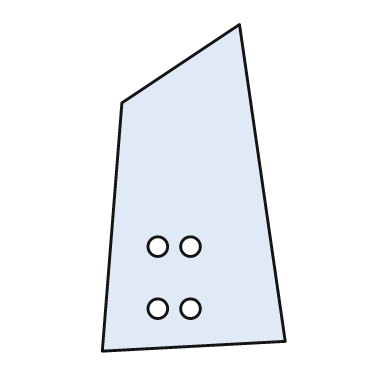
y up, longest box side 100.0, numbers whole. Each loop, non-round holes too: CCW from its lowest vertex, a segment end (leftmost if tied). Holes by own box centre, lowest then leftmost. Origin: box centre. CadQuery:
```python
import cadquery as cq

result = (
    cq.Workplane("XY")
    .moveTo(-28.0, -50.0)
    .lineTo(28.0, -47.0)
    .lineTo(14.0, 50.0)
    .lineTo(-22.0, 26.0)
    .close()
    .moveTo(-11.0, -37.0)
    .circle(3.0)
    .moveTo(-1.0, -37.0)
    .circle(3.0)
    .moveTo(-11.0, -18.0)
    .circle(3.0)
    .moveTo(-1.0, -18.0)
    .circle(3.0)
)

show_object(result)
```